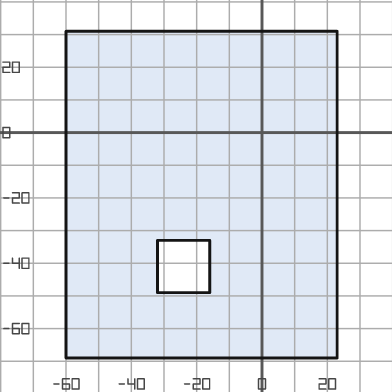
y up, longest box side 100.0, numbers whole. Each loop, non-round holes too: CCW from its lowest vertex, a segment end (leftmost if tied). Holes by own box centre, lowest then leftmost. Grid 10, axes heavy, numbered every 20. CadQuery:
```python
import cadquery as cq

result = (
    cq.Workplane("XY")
    .moveTo(-60.0, -69.0)
    .lineTo(23.0, -69.0)
    .lineTo(23.0, 31.0)
    .lineTo(-60.0, 31.0)
    .close()
    .moveTo(-32.0, -49.0)
    .lineTo(-16.0, -49.0)
    .lineTo(-16.0, -33.0)
    .lineTo(-32.0, -33.0)
    .close()
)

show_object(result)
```